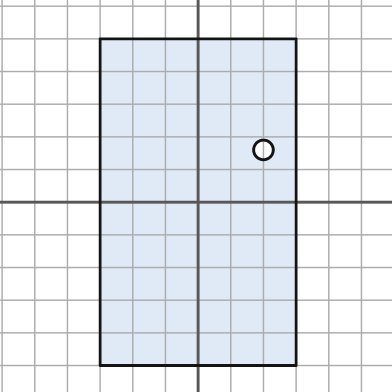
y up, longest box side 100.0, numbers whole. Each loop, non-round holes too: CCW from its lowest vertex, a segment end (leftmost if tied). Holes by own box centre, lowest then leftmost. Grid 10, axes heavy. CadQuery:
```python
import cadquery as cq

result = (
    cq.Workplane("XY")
    .moveTo(-30.0, -50.0)
    .lineTo(30.0, -50.0)
    .lineTo(30.0, 50.0)
    .lineTo(-30.0, 50.0)
    .close()
    .moveTo(20.0, 16.0)
    .circle(3.0)
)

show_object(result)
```